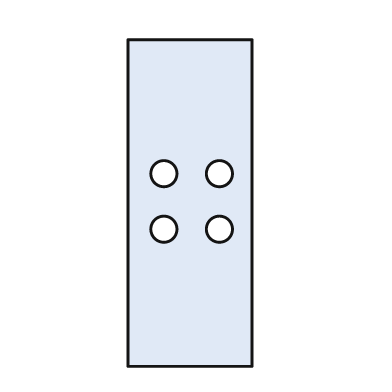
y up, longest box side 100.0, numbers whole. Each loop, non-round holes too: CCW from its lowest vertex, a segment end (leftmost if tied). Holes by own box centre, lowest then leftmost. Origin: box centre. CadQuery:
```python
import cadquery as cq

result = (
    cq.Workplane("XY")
    .moveTo(-19.0, -50.0)
    .lineTo(19.0, -50.0)
    .lineTo(19.0, 50.0)
    .lineTo(-19.0, 50.0)
    .close()
    .moveTo(-8.0, -8.0)
    .circle(4.0)
    .moveTo(9.0, -8.0)
    .circle(4.0)
    .moveTo(-8.0, 9.0)
    .circle(4.0)
    .moveTo(9.0, 9.0)
    .circle(4.0)
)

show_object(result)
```